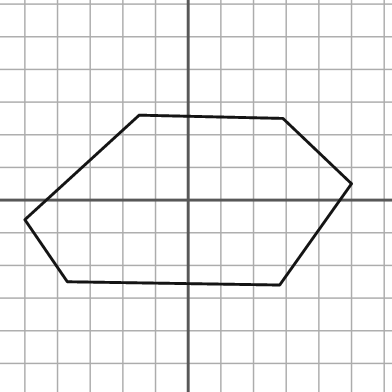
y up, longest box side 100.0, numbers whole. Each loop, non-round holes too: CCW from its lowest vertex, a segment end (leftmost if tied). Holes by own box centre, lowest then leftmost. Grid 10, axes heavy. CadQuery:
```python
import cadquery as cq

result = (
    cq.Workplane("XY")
    .moveTo(28.0, -26.0)
    .lineTo(50.0, 5.0)
    .lineTo(29.0, 25.0)
    .lineTo(-15.0, 26.0)
    .lineTo(-50.0, -6.0)
    .lineTo(-37.0, -25.0)
    .close()
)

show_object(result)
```